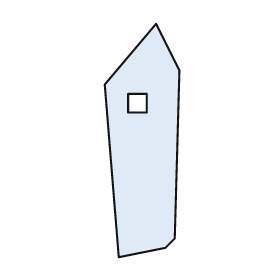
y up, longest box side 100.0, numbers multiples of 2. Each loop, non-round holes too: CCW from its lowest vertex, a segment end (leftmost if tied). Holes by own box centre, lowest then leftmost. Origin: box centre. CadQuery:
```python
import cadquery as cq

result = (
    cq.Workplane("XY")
    .moveTo(-10.0, -50.0)
    .lineTo(10.0, -46.0)
    .lineTo(14.0, -42.0)
    .lineTo(16.0, 30.0)
    .lineTo(6.0, 50.0)
    .lineTo(-16.0, 24.0)
    .close()
    .moveTo(-6.0, 12.0)
    .lineTo(2.0, 12.0)
    .lineTo(2.0, 20.0)
    .lineTo(-6.0, 20.0)
    .close()
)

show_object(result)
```